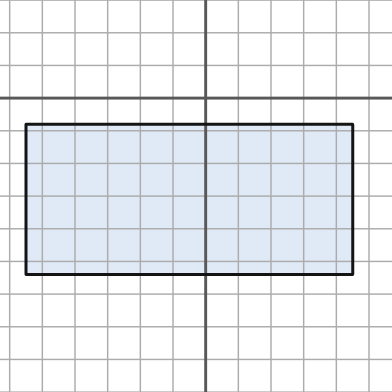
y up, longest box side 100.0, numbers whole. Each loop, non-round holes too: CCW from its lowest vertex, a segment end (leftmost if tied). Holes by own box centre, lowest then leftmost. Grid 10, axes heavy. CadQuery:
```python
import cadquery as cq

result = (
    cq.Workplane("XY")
    .moveTo(-55.0, -54.0)
    .lineTo(45.0, -54.0)
    .lineTo(45.0, -8.0)
    .lineTo(-55.0, -8.0)
    .close()
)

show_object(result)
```